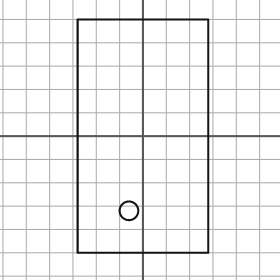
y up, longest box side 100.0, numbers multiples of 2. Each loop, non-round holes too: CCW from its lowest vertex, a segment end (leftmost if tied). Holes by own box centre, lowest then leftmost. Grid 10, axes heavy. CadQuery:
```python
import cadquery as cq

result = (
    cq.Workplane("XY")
    .moveTo(-28.0, -50.0)
    .lineTo(28.0, -50.0)
    .lineTo(28.0, 50.0)
    .lineTo(-28.0, 50.0)
    .close()
    .moveTo(-6.0, -32.0)
    .circle(4.0)
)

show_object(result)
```